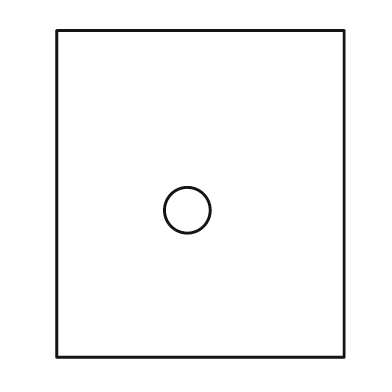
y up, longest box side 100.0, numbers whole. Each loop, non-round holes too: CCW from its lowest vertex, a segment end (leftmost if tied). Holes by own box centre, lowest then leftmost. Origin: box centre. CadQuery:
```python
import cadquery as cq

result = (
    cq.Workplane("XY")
    .moveTo(-44.0, -50.0)
    .lineTo(44.0, -50.0)
    .lineTo(44.0, 50.0)
    .lineTo(-44.0, 50.0)
    .close()
    .moveTo(-4.0, -5.0)
    .circle(7.0)
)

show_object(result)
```